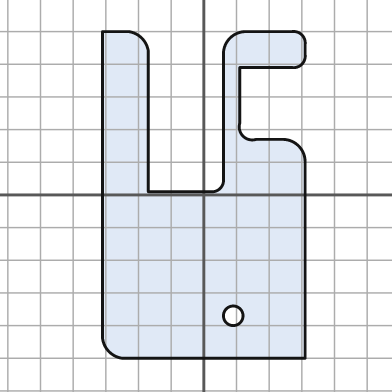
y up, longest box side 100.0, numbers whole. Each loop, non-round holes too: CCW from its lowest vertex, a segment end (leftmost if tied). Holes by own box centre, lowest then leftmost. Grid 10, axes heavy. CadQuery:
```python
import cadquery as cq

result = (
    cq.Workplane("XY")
    .moveTo(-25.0, -50.0)
    .lineTo(31.0, -50.0)
    .lineTo(31.0, 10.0)
    .threePointArc((29.0, 15.0), (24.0, 17.0))
    .lineTo(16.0, 17.0)
    .threePointArc((12.0, 18.0), (11.0, 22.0))
    .lineTo(11.0, 39.0)
    .lineTo(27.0, 39.0)
    .threePointArc((30.0, 40.0), (31.0, 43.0))
    .lineTo(31.0, 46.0)
    .threePointArc((30.0, 49.0), (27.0, 50.0))
    .lineTo(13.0, 50.0)
    .threePointArc((8.0, 48.0), (6.0, 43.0))
    .lineTo(6.0, 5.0)
    .threePointArc((5.0, 2.0), (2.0, 1.0))
    .lineTo(-17.0, 1.0)
    .lineTo(-17.0, 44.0)
    .threePointArc((-19.0, 48.0), (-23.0, 50.0))
    .lineTo(-31.0, 50.0)
    .lineTo(-31.0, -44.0)
    .threePointArc((-29.0, -48.0), (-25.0, -50.0))
    .close()
    .moveTo(9.0, -37.0)
    .circle(3.0)
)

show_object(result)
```